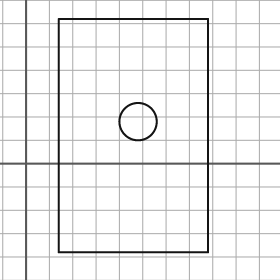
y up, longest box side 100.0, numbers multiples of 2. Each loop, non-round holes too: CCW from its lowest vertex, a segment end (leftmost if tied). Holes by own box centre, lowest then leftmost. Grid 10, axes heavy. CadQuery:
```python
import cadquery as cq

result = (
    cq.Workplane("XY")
    .moveTo(14.0, -38.0)
    .lineTo(78.0, -38.0)
    .lineTo(78.0, 62.0)
    .lineTo(14.0, 62.0)
    .close()
    .moveTo(48.0, 18.0)
    .circle(8.0)
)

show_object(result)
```